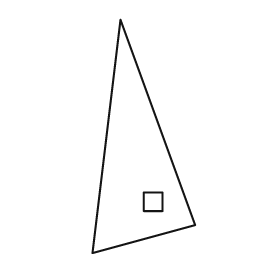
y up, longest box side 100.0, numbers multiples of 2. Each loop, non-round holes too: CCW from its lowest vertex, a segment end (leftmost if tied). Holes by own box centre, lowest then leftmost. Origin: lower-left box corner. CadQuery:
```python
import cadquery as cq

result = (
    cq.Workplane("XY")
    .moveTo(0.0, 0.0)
    .lineTo(44.0, 12.0)
    .lineTo(12.0, 100.0)
    .close()
    .moveTo(22.0, 18.0)
    .lineTo(30.0, 18.0)
    .lineTo(30.0, 26.0)
    .lineTo(22.0, 26.0)
    .close()
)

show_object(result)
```